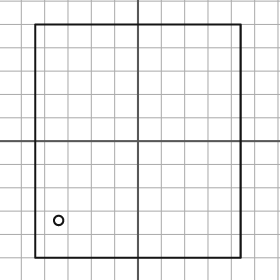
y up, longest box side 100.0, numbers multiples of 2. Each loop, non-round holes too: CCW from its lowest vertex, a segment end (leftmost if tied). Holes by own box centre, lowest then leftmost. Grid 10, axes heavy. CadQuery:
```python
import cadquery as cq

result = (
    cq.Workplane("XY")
    .moveTo(-44.0, -50.0)
    .lineTo(44.0, -50.0)
    .lineTo(44.0, 50.0)
    .lineTo(-44.0, 50.0)
    .close()
    .moveTo(-34.0, -34.0)
    .circle(2.0)
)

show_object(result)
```